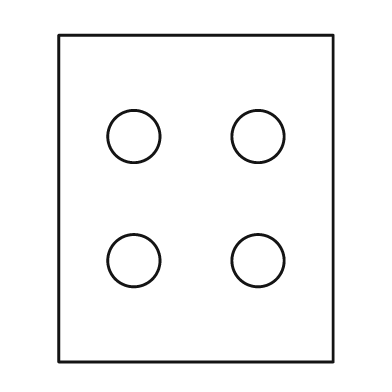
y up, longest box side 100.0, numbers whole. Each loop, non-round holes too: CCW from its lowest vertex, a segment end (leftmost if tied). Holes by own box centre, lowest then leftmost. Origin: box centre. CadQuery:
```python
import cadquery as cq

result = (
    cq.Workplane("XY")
    .moveTo(-42.0, -50.0)
    .lineTo(42.0, -50.0)
    .lineTo(42.0, 50.0)
    .lineTo(-42.0, 50.0)
    .close()
    .moveTo(-19.0, -19.0)
    .circle(8.0)
    .moveTo(19.0, -19.0)
    .circle(8.0)
    .moveTo(-19.0, 19.0)
    .circle(8.0)
    .moveTo(19.0, 19.0)
    .circle(8.0)
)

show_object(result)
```